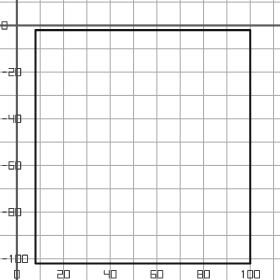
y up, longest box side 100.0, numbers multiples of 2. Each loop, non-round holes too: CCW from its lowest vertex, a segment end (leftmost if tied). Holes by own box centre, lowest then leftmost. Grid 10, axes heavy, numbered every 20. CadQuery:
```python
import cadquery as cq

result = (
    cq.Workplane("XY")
    .moveTo(8.0, -102.0)
    .lineTo(100.0, -102.0)
    .lineTo(100.0, -2.0)
    .lineTo(8.0, -2.0)
    .close()
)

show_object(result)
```